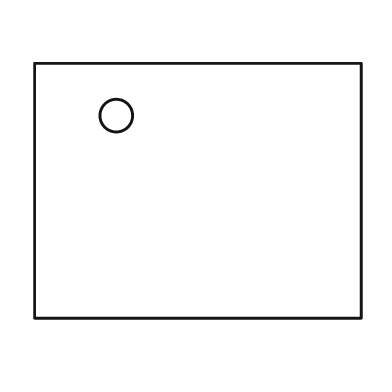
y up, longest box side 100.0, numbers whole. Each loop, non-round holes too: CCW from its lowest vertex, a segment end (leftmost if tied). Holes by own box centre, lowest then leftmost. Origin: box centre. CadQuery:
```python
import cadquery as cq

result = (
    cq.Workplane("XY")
    .moveTo(-50.0, -39.0)
    .lineTo(50.0, -39.0)
    .lineTo(50.0, 39.0)
    .lineTo(-50.0, 39.0)
    .close()
    .moveTo(-25.0, 23.0)
    .circle(5.0)
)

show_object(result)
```